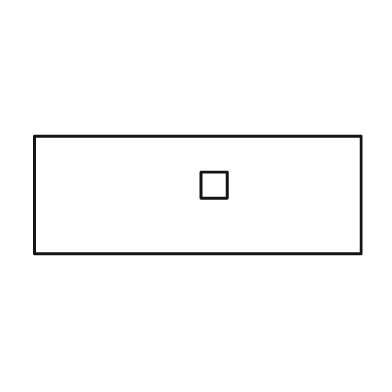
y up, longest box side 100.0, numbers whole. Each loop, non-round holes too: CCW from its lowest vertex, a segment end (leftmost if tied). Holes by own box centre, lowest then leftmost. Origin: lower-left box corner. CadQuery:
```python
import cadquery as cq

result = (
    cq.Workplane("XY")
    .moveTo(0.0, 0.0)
    .lineTo(100.0, 0.0)
    .lineTo(100.0, 36.0)
    .lineTo(0.0, 36.0)
    .close()
    .moveTo(51.0, 17.0)
    .lineTo(59.0, 17.0)
    .lineTo(59.0, 25.0)
    .lineTo(51.0, 25.0)
    .close()
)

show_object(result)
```